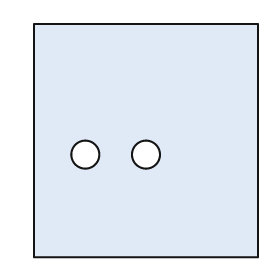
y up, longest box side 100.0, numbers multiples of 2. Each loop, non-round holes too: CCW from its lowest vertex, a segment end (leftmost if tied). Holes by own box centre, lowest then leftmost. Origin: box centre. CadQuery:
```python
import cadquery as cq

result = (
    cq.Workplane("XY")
    .moveTo(-48.0, -50.0)
    .lineTo(48.0, -50.0)
    .lineTo(48.0, 50.0)
    .lineTo(-48.0, 50.0)
    .close()
    .moveTo(-26.0, -6.0)
    .circle(6.0)
    .moveTo(0.0, -6.0)
    .circle(6.0)
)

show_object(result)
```